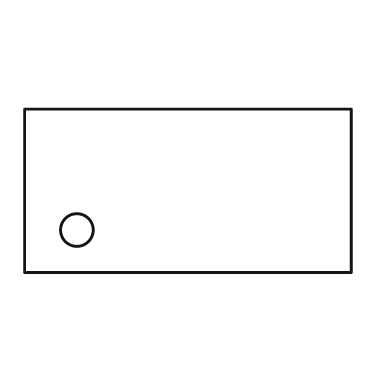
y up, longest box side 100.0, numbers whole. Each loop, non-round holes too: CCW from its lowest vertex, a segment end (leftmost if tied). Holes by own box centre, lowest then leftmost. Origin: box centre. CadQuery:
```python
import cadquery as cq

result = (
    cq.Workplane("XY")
    .moveTo(-50.0, -25.0)
    .lineTo(50.0, -25.0)
    .lineTo(50.0, 25.0)
    .lineTo(-50.0, 25.0)
    .close()
    .moveTo(-34.0, -12.0)
    .circle(5.0)
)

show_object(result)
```